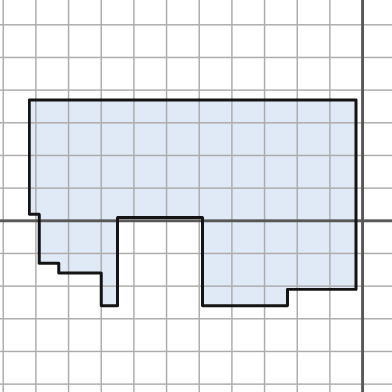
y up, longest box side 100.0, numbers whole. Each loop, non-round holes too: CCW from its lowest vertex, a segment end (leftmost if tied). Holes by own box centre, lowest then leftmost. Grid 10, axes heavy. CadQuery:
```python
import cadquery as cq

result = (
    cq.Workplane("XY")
    .moveTo(-80.0, -26.0)
    .lineTo(-75.0, -26.0)
    .lineTo(-75.0, 1.0)
    .lineTo(-49.0, 1.0)
    .lineTo(-49.0, -26.0)
    .lineTo(-23.0, -26.0)
    .lineTo(-23.0, -21.0)
    .lineTo(-2.0, -21.0)
    .lineTo(-2.0, 37.0)
    .lineTo(-102.0, 37.0)
    .lineTo(-102.0, 2.0)
    .lineTo(-99.0, 2.0)
    .lineTo(-99.0, -13.0)
    .lineTo(-93.0, -13.0)
    .lineTo(-93.0, -16.0)
    .lineTo(-80.0, -16.0)
    .close()
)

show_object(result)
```